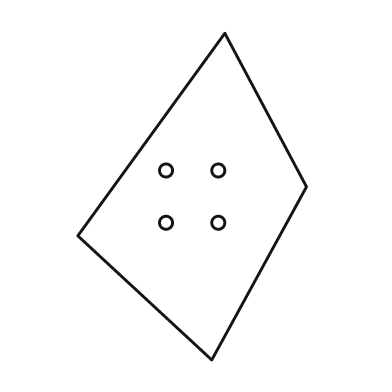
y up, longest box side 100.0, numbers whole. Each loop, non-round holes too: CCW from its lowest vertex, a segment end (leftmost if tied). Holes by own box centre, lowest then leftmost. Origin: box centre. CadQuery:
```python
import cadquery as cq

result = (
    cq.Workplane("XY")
    .moveTo(6.0, -50.0)
    .lineTo(35.0, 3.0)
    .lineTo(10.0, 50.0)
    .lineTo(-35.0, -12.0)
    .close()
    .moveTo(-8.0, -8.0)
    .circle(2.0)
    .moveTo(8.0, -8.0)
    .circle(2.0)
    .moveTo(-8.0, 8.0)
    .circle(2.0)
    .moveTo(8.0, 8.0)
    .circle(2.0)
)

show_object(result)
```